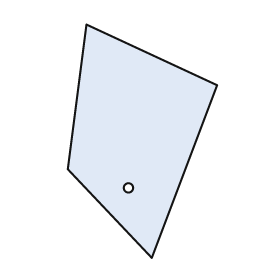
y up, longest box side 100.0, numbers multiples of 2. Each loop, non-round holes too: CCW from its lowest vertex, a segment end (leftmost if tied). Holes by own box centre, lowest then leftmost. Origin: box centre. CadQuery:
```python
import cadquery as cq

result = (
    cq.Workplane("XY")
    .moveTo(4.0, -50.0)
    .lineTo(32.0, 24.0)
    .lineTo(-24.0, 50.0)
    .lineTo(-32.0, -12.0)
    .close()
    .moveTo(-6.0, -20.0)
    .circle(2.0)
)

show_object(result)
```